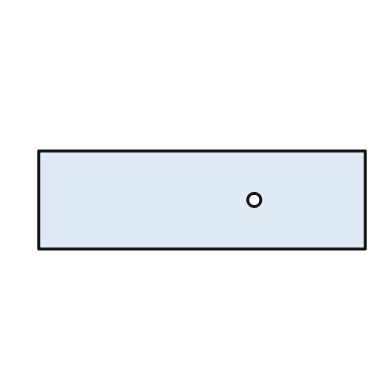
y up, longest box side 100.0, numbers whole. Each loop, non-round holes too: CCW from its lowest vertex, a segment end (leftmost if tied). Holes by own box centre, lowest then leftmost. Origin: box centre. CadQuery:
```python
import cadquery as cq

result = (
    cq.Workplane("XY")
    .moveTo(-50.0, -15.0)
    .lineTo(50.0, -15.0)
    .lineTo(50.0, 15.0)
    .lineTo(-50.0, 15.0)
    .close()
    .moveTo(16.0, 0.0)
    .circle(2.0)
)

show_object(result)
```